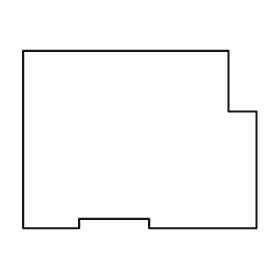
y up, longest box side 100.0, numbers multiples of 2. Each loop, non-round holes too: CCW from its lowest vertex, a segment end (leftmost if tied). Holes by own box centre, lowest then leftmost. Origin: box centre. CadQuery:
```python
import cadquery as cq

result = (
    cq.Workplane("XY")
    .moveTo(-50.0, -38.0)
    .lineTo(-26.0, -38.0)
    .lineTo(-26.0, -34.0)
    .lineTo(4.0, -34.0)
    .lineTo(4.0, -38.0)
    .lineTo(50.0, -38.0)
    .lineTo(50.0, 12.0)
    .lineTo(38.0, 12.0)
    .lineTo(38.0, 38.0)
    .lineTo(-50.0, 38.0)
    .close()
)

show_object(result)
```